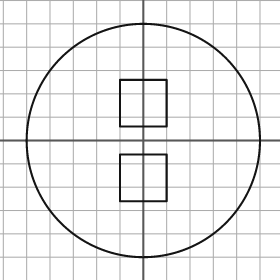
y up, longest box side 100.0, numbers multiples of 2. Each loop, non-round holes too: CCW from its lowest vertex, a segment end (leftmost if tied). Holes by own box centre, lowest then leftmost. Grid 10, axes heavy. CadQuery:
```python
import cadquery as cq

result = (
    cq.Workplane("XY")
    .moveTo(0.0, 0.0)
    .circle(50.0)
    .moveTo(-10.0, -26.0)
    .lineTo(10.0, -26.0)
    .lineTo(10.0, -6.0)
    .lineTo(-10.0, -6.0)
    .close()
    .moveTo(-10.0, 6.0)
    .lineTo(10.0, 6.0)
    .lineTo(10.0, 26.0)
    .lineTo(-10.0, 26.0)
    .close()
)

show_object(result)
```